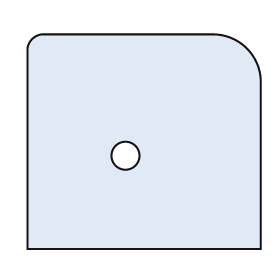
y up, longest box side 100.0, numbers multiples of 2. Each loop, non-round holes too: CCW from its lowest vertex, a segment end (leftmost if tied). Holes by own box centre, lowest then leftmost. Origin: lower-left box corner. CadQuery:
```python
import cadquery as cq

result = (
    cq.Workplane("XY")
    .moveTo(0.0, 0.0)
    .lineTo(100.0, 0.0)
    .lineTo(100.0, 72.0)
    .threePointArc((94.0, 86.0), (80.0, 92.0))
    .lineTo(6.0, 92.0)
    .threePointArc((2.0, 90.0), (0.0, 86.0))
    .close()
    .moveTo(42.0, 40.0)
    .circle(6.0)
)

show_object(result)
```